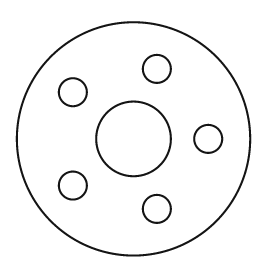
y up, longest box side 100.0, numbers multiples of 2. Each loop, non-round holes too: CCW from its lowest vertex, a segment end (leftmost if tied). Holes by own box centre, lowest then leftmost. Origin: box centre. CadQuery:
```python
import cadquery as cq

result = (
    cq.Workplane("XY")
    .moveTo(0.0, 0.0)
    .circle(50.0)
    .moveTo(10.0, -30.0)
    .circle(6.0)
    .moveTo(-26.0, -20.0)
    .circle(6.0)
    .moveTo(0.0, 0.0)
    .circle(16.0)
    .moveTo(32.0, 0.0)
    .circle(6.0)
    .moveTo(-26.0, 20.0)
    .circle(6.0)
    .moveTo(10.0, 30.0)
    .circle(6.0)
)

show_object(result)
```